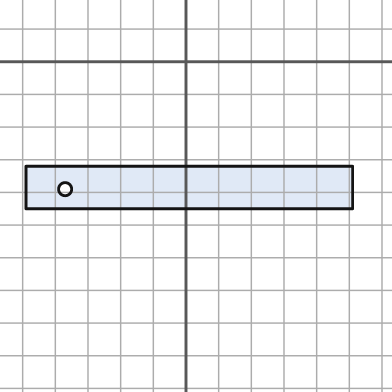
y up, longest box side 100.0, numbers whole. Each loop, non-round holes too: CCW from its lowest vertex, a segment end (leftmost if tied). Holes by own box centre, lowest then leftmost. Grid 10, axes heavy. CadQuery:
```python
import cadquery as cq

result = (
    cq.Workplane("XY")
    .moveTo(-49.0, -45.0)
    .lineTo(51.0, -45.0)
    .lineTo(51.0, -32.0)
    .lineTo(-49.0, -32.0)
    .close()
    .moveTo(-37.0, -39.0)
    .circle(2.0)
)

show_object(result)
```